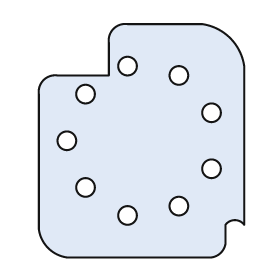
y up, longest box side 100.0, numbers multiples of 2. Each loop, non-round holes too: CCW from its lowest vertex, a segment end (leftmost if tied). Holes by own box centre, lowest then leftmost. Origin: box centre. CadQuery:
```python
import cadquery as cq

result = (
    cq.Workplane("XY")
    .moveTo(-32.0, -50.0)
    .lineTo(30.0, -50.0)
    .threePointArc((34.0, -48.0), (36.0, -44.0))
    .lineTo(36.0, -36.0)
    .threePointArc((40.0, -34.0), (44.0, -36.0))
    .lineTo(44.0, 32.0)
    .threePointArc((38.0, 44.0), (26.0, 50.0))
    .lineTo(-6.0, 50.0)
    .threePointArc((-12.0, 48.0), (-14.0, 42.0))
    .lineTo(-14.0, 28.0)
    .lineTo(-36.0, 28.0)
    .threePointArc((-42.0, 26.0), (-44.0, 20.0))
    .lineTo(-44.0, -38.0)
    .threePointArc((-40.0, -46.0), (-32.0, -50.0))
    .close()
    .moveTo(-6.0, -32.0)
    .circle(4.0)
    .moveTo(16.0, -28.0)
    .circle(4.0)
    .moveTo(-24.0, -20.0)
    .circle(4.0)
    .moveTo(30.0, -12.0)
    .circle(4.0)
    .moveTo(-32.0, 0.0)
    .circle(4.0)
    .moveTo(30.0, 12.0)
    .circle(4.0)
    .moveTo(-24.0, 20.0)
    .circle(4.0)
    .moveTo(16.0, 28.0)
    .circle(4.0)
    .moveTo(-6.0, 32.0)
    .circle(4.0)
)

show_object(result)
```